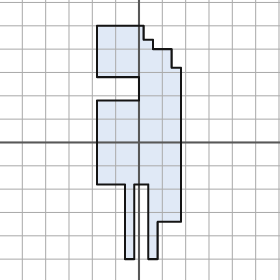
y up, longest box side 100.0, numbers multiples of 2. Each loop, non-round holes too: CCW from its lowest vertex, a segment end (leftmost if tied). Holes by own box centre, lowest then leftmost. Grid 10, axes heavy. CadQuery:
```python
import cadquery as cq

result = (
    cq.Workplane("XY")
    .moveTo(-6.0, -50.0)
    .lineTo(-2.0, -50.0)
    .lineTo(-2.0, -18.0)
    .lineTo(4.0, -18.0)
    .lineTo(4.0, -50.0)
    .lineTo(8.0, -50.0)
    .lineTo(8.0, -34.0)
    .lineTo(18.0, -34.0)
    .lineTo(18.0, 32.0)
    .lineTo(14.0, 32.0)
    .lineTo(14.0, 40.0)
    .lineTo(6.0, 40.0)
    .lineTo(6.0, 44.0)
    .lineTo(2.0, 44.0)
    .lineTo(2.0, 50.0)
    .lineTo(-18.0, 50.0)
    .lineTo(-18.0, 28.0)
    .lineTo(0.0, 28.0)
    .lineTo(0.0, 18.0)
    .lineTo(-18.0, 18.0)
    .lineTo(-18.0, -18.0)
    .lineTo(-6.0, -18.0)
    .close()
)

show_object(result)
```